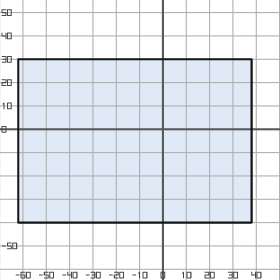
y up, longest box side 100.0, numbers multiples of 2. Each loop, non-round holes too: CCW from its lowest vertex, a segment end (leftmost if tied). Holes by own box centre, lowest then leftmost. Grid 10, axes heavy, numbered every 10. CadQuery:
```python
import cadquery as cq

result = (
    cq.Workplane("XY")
    .moveTo(-62.0, -40.0)
    .lineTo(38.0, -40.0)
    .lineTo(38.0, 30.0)
    .lineTo(-62.0, 30.0)
    .close()
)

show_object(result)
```